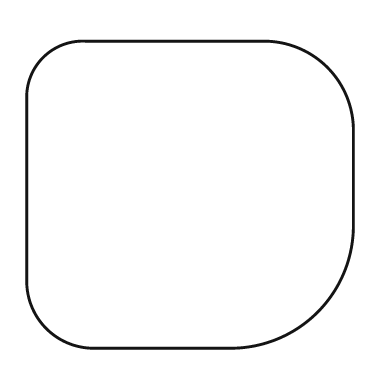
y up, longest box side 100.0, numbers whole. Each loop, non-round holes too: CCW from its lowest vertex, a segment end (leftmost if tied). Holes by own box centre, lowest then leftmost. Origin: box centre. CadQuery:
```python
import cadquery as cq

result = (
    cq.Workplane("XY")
    .moveTo(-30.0, -47.0)
    .lineTo(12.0, -47.0)
    .threePointArc((39.0, -36.0), (50.0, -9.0))
    .lineTo(50.0, 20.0)
    .threePointArc((42.0, 39.0), (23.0, 47.0))
    .lineTo(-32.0, 47.0)
    .threePointArc((-45.0, 42.0), (-50.0, 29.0))
    .lineTo(-50.0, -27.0)
    .threePointArc((-44.0, -41.0), (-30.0, -47.0))
    .close()
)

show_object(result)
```